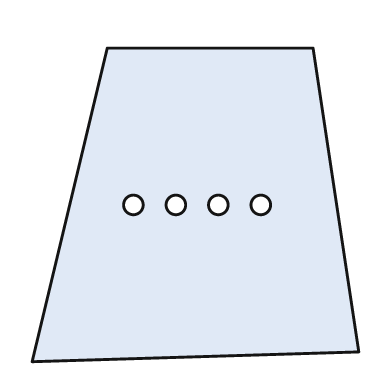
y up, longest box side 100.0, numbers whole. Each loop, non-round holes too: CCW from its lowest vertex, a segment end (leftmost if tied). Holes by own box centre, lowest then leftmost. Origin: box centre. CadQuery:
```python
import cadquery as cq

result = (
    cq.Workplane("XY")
    .moveTo(-50.0, -48.0)
    .lineTo(50.0, -45.0)
    .lineTo(36.0, 48.0)
    .lineTo(-27.0, 48.0)
    .close()
    .moveTo(-19.0, 0.0)
    .circle(3.0)
    .moveTo(-6.0, 0.0)
    .circle(3.0)
    .moveTo(7.0, 0.0)
    .circle(3.0)
    .moveTo(20.0, 0.0)
    .circle(3.0)
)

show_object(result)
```